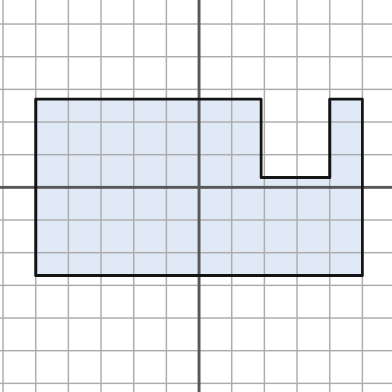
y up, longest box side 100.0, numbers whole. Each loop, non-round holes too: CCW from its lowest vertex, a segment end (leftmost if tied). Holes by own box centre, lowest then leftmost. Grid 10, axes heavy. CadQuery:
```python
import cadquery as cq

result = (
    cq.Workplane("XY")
    .moveTo(-50.0, -27.0)
    .lineTo(50.0, -27.0)
    .lineTo(50.0, 27.0)
    .lineTo(40.0, 27.0)
    .lineTo(40.0, 3.0)
    .lineTo(19.0, 3.0)
    .lineTo(19.0, 27.0)
    .lineTo(-50.0, 27.0)
    .close()
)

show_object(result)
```